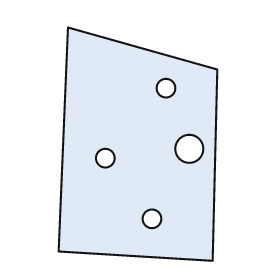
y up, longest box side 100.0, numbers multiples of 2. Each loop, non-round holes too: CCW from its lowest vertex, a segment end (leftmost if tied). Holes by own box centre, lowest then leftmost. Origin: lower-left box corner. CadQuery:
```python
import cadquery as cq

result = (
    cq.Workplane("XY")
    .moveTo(66.0, 0.0)
    .lineTo(68.0, 82.0)
    .lineTo(4.0, 100.0)
    .lineTo(0.0, 4.0)
    .close()
    .moveTo(40.0, 18.0)
    .circle(4.0)
    .moveTo(20.0, 44.0)
    .circle(4.0)
    .moveTo(56.0, 48.0)
    .circle(6.0)
    .moveTo(46.0, 74.0)
    .circle(4.0)
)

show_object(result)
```